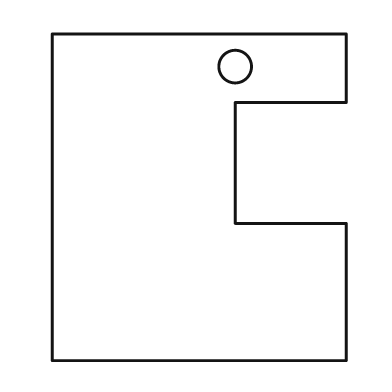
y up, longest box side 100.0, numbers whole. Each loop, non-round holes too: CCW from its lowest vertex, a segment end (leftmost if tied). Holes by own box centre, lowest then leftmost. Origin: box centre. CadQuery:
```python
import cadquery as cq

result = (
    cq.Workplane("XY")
    .moveTo(-45.0, -50.0)
    .lineTo(45.0, -50.0)
    .lineTo(45.0, -8.0)
    .lineTo(11.0, -8.0)
    .lineTo(11.0, 29.0)
    .lineTo(45.0, 29.0)
    .lineTo(45.0, 50.0)
    .lineTo(-45.0, 50.0)
    .close()
    .moveTo(11.0, 40.0)
    .circle(5.0)
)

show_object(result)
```